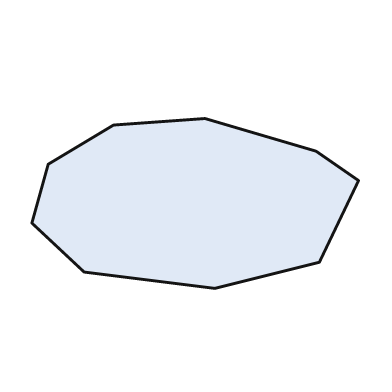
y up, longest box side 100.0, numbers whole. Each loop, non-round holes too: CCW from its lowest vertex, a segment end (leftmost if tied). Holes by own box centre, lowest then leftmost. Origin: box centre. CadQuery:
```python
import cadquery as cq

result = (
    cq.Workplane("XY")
    .moveTo(6.0, -26.0)
    .lineTo(38.0, -18.0)
    .lineTo(50.0, 7.0)
    .lineTo(37.0, 16.0)
    .lineTo(3.0, 26.0)
    .lineTo(-25.0, 24.0)
    .lineTo(-45.0, 12.0)
    .lineTo(-50.0, -6.0)
    .lineTo(-34.0, -21.0)
    .close()
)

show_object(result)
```